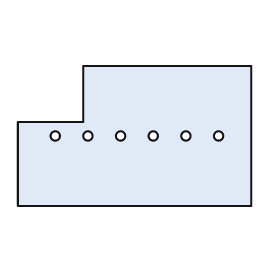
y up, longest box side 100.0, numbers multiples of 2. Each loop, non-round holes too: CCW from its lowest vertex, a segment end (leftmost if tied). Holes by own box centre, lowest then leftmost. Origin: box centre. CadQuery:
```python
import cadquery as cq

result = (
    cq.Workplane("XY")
    .moveTo(-50.0, -30.0)
    .lineTo(50.0, -30.0)
    .lineTo(50.0, 30.0)
    .lineTo(-22.0, 30.0)
    .lineTo(-22.0, 6.0)
    .lineTo(-50.0, 6.0)
    .close()
    .moveTo(-34.0, 0.0)
    .circle(2.0)
    .moveTo(-20.0, 0.0)
    .circle(2.0)
    .moveTo(-6.0, 0.0)
    .circle(2.0)
    .moveTo(8.0, 0.0)
    .circle(2.0)
    .moveTo(22.0, 0.0)
    .circle(2.0)
    .moveTo(36.0, 0.0)
    .circle(2.0)
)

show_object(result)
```